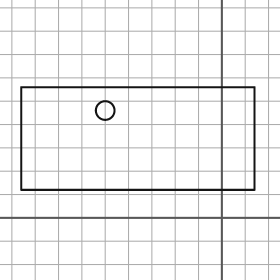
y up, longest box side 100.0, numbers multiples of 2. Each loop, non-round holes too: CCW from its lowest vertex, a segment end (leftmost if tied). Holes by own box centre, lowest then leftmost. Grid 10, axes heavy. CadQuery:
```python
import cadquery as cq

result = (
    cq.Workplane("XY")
    .moveTo(-86.0, 12.0)
    .lineTo(14.0, 12.0)
    .lineTo(14.0, 56.0)
    .lineTo(-86.0, 56.0)
    .close()
    .moveTo(-50.0, 46.0)
    .circle(4.0)
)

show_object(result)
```